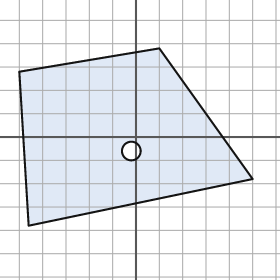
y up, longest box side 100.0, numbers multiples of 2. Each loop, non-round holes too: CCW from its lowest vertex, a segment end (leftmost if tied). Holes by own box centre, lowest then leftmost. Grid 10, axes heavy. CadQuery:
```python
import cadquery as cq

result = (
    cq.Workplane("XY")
    .moveTo(-46.0, -38.0)
    .lineTo(50.0, -18.0)
    .lineTo(10.0, 38.0)
    .lineTo(-50.0, 28.0)
    .close()
    .moveTo(-2.0, -6.0)
    .circle(4.0)
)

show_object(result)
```